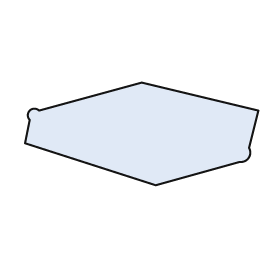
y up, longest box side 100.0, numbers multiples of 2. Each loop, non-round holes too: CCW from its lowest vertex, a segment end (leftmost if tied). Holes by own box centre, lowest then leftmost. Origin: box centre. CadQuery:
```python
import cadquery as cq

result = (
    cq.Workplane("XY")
    .moveTo(6.0, -22.0)
    .lineTo(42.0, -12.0)
    .threePointArc((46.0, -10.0), (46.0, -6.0))
    .lineTo(50.0, 10.0)
    .lineTo(0.0, 22.0)
    .lineTo(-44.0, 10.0)
    .threePointArc((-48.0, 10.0), (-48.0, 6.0))
    .lineTo(-50.0, -4.0)
    .close()
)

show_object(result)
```